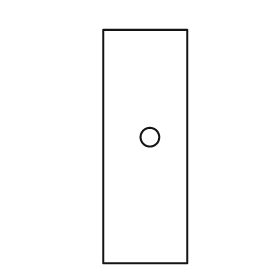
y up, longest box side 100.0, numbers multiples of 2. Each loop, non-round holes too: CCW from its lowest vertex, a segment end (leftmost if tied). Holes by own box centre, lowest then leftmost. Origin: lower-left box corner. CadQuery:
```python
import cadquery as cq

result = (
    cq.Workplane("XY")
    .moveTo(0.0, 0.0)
    .lineTo(36.0, 0.0)
    .lineTo(36.0, 100.0)
    .lineTo(0.0, 100.0)
    .close()
    .moveTo(20.0, 54.0)
    .circle(4.0)
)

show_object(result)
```